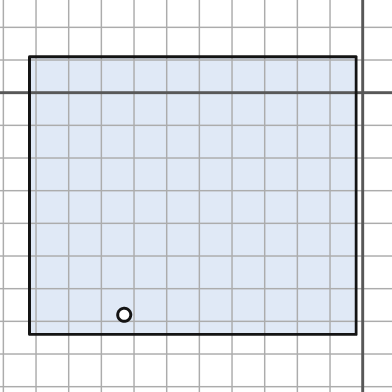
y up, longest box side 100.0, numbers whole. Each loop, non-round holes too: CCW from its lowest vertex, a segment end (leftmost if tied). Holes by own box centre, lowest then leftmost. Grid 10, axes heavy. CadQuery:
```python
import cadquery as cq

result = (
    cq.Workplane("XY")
    .moveTo(-102.0, -74.0)
    .lineTo(-2.0, -74.0)
    .lineTo(-2.0, 11.0)
    .lineTo(-102.0, 11.0)
    .close()
    .moveTo(-73.0, -68.0)
    .circle(2.0)
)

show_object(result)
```